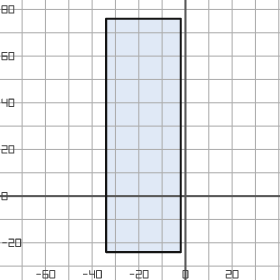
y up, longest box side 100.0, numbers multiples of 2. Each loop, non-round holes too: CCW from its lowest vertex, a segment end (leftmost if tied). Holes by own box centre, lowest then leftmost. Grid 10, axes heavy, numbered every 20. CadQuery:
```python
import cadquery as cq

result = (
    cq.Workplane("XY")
    .moveTo(-34.0, -24.0)
    .lineTo(-2.0, -24.0)
    .lineTo(-2.0, 76.0)
    .lineTo(-34.0, 76.0)
    .close()
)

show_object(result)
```